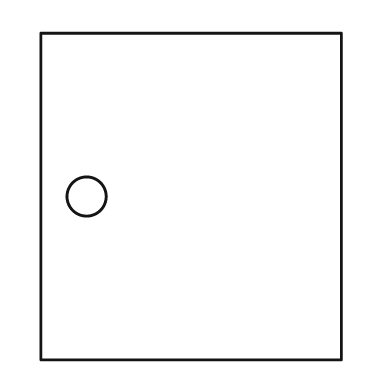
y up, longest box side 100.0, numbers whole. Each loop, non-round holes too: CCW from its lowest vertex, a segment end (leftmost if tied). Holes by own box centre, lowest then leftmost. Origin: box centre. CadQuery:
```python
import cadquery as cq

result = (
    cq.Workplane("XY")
    .moveTo(-46.0, -50.0)
    .lineTo(46.0, -50.0)
    .lineTo(46.0, 50.0)
    .lineTo(-46.0, 50.0)
    .close()
    .moveTo(-32.0, 0.0)
    .circle(6.0)
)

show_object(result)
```